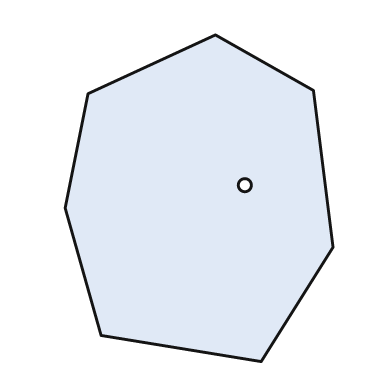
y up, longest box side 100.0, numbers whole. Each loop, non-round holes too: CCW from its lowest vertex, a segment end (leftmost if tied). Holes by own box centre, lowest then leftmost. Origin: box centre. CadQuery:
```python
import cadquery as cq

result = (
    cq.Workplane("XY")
    .moveTo(19.0, -50.0)
    .lineTo(41.0, -15.0)
    .lineTo(35.0, 33.0)
    .lineTo(5.0, 50.0)
    .lineTo(-34.0, 32.0)
    .lineTo(-41.0, -3.0)
    .lineTo(-30.0, -42.0)
    .close()
    .moveTo(14.0, 4.0)
    .circle(2.0)
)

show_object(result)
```